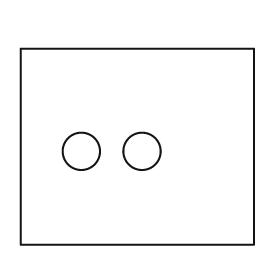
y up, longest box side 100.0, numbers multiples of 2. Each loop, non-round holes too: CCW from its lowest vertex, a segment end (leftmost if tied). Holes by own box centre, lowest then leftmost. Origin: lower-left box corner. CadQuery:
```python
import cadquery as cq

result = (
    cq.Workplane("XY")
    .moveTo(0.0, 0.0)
    .lineTo(100.0, 0.0)
    .lineTo(100.0, 84.0)
    .lineTo(0.0, 84.0)
    .close()
    .moveTo(26.0, 40.0)
    .circle(8.0)
    .moveTo(52.0, 40.0)
    .circle(8.0)
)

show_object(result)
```